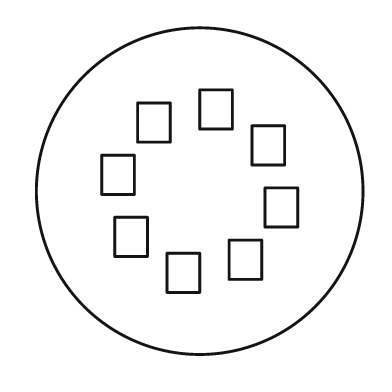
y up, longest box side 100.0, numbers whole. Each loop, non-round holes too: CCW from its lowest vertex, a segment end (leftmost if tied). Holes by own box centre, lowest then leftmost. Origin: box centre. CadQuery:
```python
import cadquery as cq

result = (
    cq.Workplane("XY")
    .moveTo(0.0, 0.0)
    .circle(50.0)
    .moveTo(-10.0, -31.0)
    .lineTo(0.0, -31.0)
    .lineTo(0.0, -19.0)
    .lineTo(-10.0, -19.0)
    .close()
    .moveTo(9.0, -27.0)
    .lineTo(19.0, -27.0)
    .lineTo(19.0, -15.0)
    .lineTo(9.0, -15.0)
    .close()
    .moveTo(-26.0, -20.0)
    .lineTo(-16.0, -20.0)
    .lineTo(-16.0, -8.0)
    .lineTo(-26.0, -8.0)
    .close()
    .moveTo(20.0, -11.0)
    .lineTo(30.0, -11.0)
    .lineTo(30.0, 1.0)
    .lineTo(20.0, 1.0)
    .close()
    .moveTo(-30.0, -1.0)
    .lineTo(-20.0, -1.0)
    .lineTo(-20.0, 11.0)
    .lineTo(-30.0, 11.0)
    .close()
    .moveTo(16.0, 8.0)
    .lineTo(26.0, 8.0)
    .lineTo(26.0, 20.0)
    .lineTo(16.0, 20.0)
    .close()
    .moveTo(-19.0, 15.0)
    .lineTo(-9.0, 15.0)
    .lineTo(-9.0, 27.0)
    .lineTo(-19.0, 27.0)
    .close()
    .moveTo(0.0, 19.0)
    .lineTo(10.0, 19.0)
    .lineTo(10.0, 31.0)
    .lineTo(0.0, 31.0)
    .close()
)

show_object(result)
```